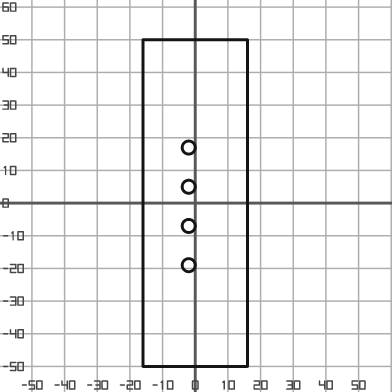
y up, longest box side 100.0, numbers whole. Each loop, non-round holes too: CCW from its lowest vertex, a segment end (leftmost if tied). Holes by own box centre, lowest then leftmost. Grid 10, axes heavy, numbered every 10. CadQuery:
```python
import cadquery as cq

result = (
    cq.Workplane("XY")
    .moveTo(-16.0, -50.0)
    .lineTo(16.0, -50.0)
    .lineTo(16.0, 50.0)
    .lineTo(-16.0, 50.0)
    .close()
    .moveTo(-2.0, -19.0)
    .circle(2.0)
    .moveTo(-2.0, -7.0)
    .circle(2.0)
    .moveTo(-2.0, 5.0)
    .circle(2.0)
    .moveTo(-2.0, 17.0)
    .circle(2.0)
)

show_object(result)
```